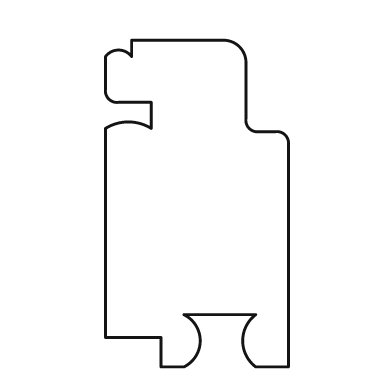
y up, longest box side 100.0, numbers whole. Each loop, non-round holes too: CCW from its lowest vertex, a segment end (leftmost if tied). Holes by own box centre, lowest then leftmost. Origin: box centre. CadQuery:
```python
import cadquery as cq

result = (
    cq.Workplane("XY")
    .moveTo(-11.0, -50.0)
    .lineTo(-4.0, -50.0)
    .threePointArc((1.0, -42.0), (-4.0, -34.0))
    .lineTo(18.0, -34.0)
    .threePointArc((14.0, -42.0), (18.0, -50.0))
    .lineTo(28.0, -50.0)
    .lineTo(28.0, 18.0)
    .threePointArc((27.0, 21.0), (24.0, 22.0))
    .lineTo(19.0, 22.0)
    .threePointArc((16.0, 23.0), (15.0, 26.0))
    .lineTo(15.0, 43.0)
    .threePointArc((13.0, 48.0), (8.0, 50.0))
    .lineTo(-20.0, 50.0)
    .lineTo(-20.0, 45.0)
    .threePointArc((-24.0, 47.0), (-28.0, 45.0))
    .lineTo(-28.0, 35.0)
    .threePointArc((-27.0, 32.0), (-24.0, 31.0))
    .lineTo(-14.0, 31.0)
    .lineTo(-14.0, 23.0)
    .threePointArc((-21.0, 25.0), (-28.0, 23.0))
    .lineTo(-28.0, -41.0)
    .lineTo(-11.0, -41.0)
    .close()
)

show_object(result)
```